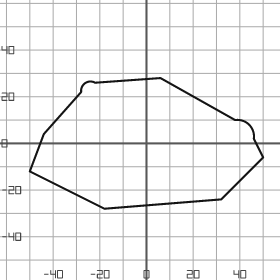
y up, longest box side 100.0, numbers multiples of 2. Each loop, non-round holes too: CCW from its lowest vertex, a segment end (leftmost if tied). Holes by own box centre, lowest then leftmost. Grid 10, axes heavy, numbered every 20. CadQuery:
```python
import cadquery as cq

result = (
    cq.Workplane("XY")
    .moveTo(-18.0, -28.0)
    .lineTo(32.0, -24.0)
    .lineTo(50.0, -6.0)
    .lineTo(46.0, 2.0)
    .threePointArc((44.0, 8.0), (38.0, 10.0))
    .lineTo(6.0, 28.0)
    .lineTo(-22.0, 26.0)
    .threePointArc((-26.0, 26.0), (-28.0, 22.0))
    .lineTo(-44.0, 4.0)
    .lineTo(-50.0, -12.0)
    .close()
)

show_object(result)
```